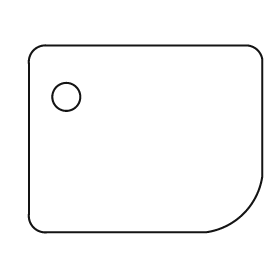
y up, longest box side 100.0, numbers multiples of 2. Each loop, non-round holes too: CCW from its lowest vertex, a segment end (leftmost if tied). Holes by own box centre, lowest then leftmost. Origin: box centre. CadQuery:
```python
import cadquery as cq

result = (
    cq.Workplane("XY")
    .moveTo(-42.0, -40.0)
    .lineTo(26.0, -40.0)
    .threePointArc((42.0, -32.0), (50.0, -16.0))
    .lineTo(50.0, 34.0)
    .threePointArc((48.0, 38.0), (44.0, 40.0))
    .lineTo(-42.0, 40.0)
    .threePointArc((-48.0, 38.0), (-50.0, 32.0))
    .lineTo(-50.0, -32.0)
    .threePointArc((-48.0, -38.0), (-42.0, -40.0))
    .close()
    .moveTo(-34.0, 18.0)
    .circle(6.0)
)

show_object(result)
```